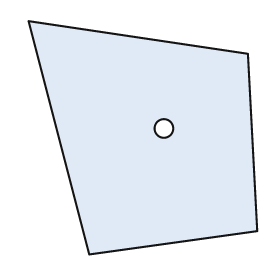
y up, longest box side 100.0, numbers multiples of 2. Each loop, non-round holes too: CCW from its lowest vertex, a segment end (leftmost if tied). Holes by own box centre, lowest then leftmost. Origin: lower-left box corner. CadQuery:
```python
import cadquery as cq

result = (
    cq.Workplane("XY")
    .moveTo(26.0, 0.0)
    .lineTo(98.0, 10.0)
    .lineTo(94.0, 86.0)
    .lineTo(0.0, 100.0)
    .close()
    .moveTo(58.0, 54.0)
    .circle(4.0)
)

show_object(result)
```